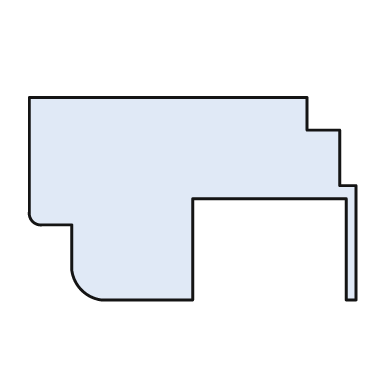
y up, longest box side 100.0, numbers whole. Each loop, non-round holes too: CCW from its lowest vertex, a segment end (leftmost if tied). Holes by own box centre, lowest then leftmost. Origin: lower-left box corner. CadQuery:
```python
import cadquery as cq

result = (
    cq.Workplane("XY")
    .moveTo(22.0, 0.0)
    .lineTo(50.0, 0.0)
    .lineTo(50.0, 31.0)
    .lineTo(97.0, 31.0)
    .lineTo(97.0, 0.0)
    .lineTo(100.0, 0.0)
    .lineTo(100.0, 35.0)
    .lineTo(95.0, 35.0)
    .lineTo(95.0, 52.0)
    .lineTo(85.0, 52.0)
    .lineTo(85.0, 62.0)
    .lineTo(0.0, 62.0)
    .lineTo(0.0, 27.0)
    .threePointArc((1.0, 24.0), (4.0, 23.0))
    .lineTo(13.0, 23.0)
    .lineTo(13.0, 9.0)
    .threePointArc((16.0, 3.0), (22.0, 0.0))
    .close()
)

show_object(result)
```